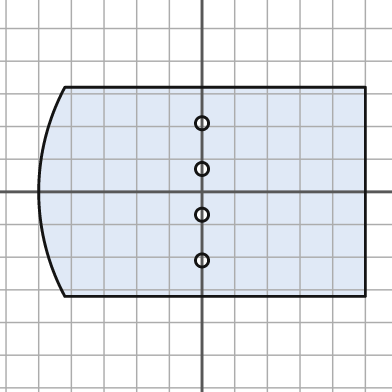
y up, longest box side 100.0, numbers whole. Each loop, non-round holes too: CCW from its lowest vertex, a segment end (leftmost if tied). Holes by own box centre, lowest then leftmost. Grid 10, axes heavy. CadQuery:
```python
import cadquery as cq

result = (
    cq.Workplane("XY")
    .moveTo(-42.0, -32.0)
    .lineTo(50.0, -32.0)
    .lineTo(50.0, 32.0)
    .lineTo(-42.0, 32.0)
    .threePointArc((-50.0, 0.0), (-42.0, -32.0))
    .close()
    .moveTo(0.0, -21.0)
    .circle(2.0)
    .moveTo(0.0, -7.0)
    .circle(2.0)
    .moveTo(0.0, 7.0)
    .circle(2.0)
    .moveTo(0.0, 21.0)
    .circle(2.0)
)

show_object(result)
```